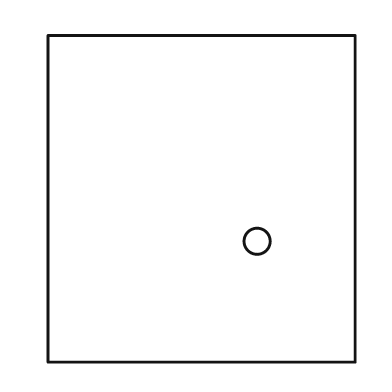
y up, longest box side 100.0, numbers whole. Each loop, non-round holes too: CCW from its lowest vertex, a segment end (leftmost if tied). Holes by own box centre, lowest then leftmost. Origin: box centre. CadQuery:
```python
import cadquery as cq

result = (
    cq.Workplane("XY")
    .moveTo(-47.0, -50.0)
    .lineTo(47.0, -50.0)
    .lineTo(47.0, 50.0)
    .lineTo(-47.0, 50.0)
    .close()
    .moveTo(17.0, -13.0)
    .circle(4.0)
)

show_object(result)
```